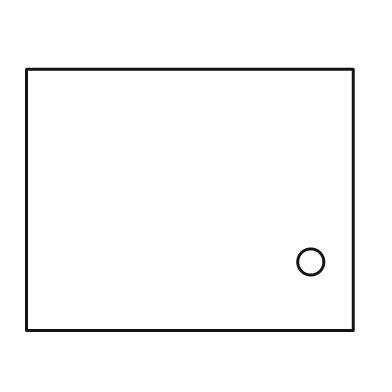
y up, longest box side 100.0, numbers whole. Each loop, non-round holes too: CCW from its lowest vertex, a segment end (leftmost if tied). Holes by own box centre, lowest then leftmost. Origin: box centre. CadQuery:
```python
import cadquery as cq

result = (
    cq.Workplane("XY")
    .moveTo(-50.0, -40.0)
    .lineTo(50.0, -40.0)
    .lineTo(50.0, 40.0)
    .lineTo(-50.0, 40.0)
    .close()
    .moveTo(37.0, -19.0)
    .circle(4.0)
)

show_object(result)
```